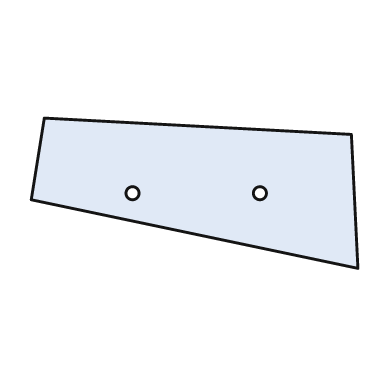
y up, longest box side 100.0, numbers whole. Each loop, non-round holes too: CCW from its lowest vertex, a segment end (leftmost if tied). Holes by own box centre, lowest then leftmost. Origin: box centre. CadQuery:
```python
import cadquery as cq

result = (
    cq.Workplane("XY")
    .moveTo(50.0, -23.0)
    .lineTo(48.0, 18.0)
    .lineTo(-46.0, 23.0)
    .lineTo(-50.0, -2.0)
    .close()
    .moveTo(-19.0, 0.0)
    .circle(2.0)
    .moveTo(20.0, 0.0)
    .circle(2.0)
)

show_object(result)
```